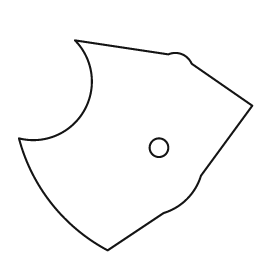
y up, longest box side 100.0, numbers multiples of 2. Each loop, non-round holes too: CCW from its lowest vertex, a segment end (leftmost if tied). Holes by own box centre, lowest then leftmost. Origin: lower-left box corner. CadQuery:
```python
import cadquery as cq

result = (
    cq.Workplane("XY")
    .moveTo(38.0, 0.0)
    .lineTo(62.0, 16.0)
    .threePointArc((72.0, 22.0), (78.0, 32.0))
    .lineTo(100.0, 62.0)
    .lineTo(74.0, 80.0)
    .threePointArc((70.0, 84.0), (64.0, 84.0))
    .lineTo(24.0, 90.0)
    .threePointArc((28.0, 60.0), (0.0, 48.0))
    .threePointArc((14.0, 20.0), (38.0, 0.0))
    .close()
    .moveTo(60.0, 44.0)
    .circle(4.0)
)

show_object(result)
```